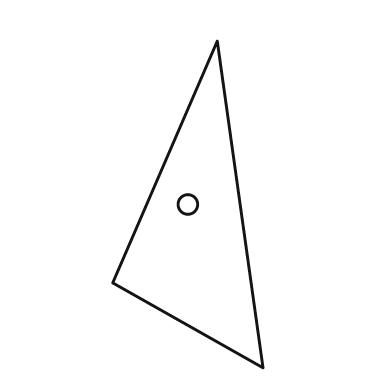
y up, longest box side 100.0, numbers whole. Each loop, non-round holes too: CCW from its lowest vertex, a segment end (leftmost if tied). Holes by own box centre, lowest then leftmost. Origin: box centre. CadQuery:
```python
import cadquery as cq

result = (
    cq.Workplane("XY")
    .moveTo(23.0, -50.0)
    .lineTo(9.0, 50.0)
    .lineTo(-23.0, -24.0)
    .close()
    .moveTo(0.0, 0.0)
    .circle(3.0)
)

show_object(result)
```